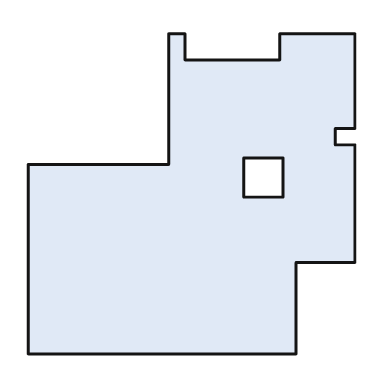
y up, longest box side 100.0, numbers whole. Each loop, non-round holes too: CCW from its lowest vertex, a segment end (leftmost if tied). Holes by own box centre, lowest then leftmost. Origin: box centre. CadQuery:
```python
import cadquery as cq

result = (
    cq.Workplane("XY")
    .moveTo(-50.0, -49.0)
    .lineTo(32.0, -49.0)
    .lineTo(32.0, -21.0)
    .lineTo(50.0, -21.0)
    .lineTo(50.0, 15.0)
    .lineTo(44.0, 15.0)
    .lineTo(44.0, 20.0)
    .lineTo(50.0, 20.0)
    .lineTo(50.0, 49.0)
    .lineTo(27.0, 49.0)
    .lineTo(27.0, 41.0)
    .lineTo(-2.0, 41.0)
    .lineTo(-2.0, 49.0)
    .lineTo(-7.0, 49.0)
    .lineTo(-7.0, 9.0)
    .lineTo(-50.0, 9.0)
    .close()
    .moveTo(16.0, -1.0)
    .lineTo(28.0, -1.0)
    .lineTo(28.0, 11.0)
    .lineTo(16.0, 11.0)
    .close()
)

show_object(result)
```